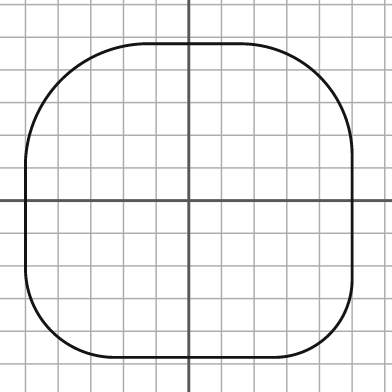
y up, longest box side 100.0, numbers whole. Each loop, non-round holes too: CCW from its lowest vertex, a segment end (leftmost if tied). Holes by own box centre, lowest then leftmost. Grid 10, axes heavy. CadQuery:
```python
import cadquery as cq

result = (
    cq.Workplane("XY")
    .moveTo(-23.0, -48.0)
    .lineTo(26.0, -48.0)
    .threePointArc((43.0, -41.0), (50.0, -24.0))
    .lineTo(50.0, 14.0)
    .threePointArc((40.0, 38.0), (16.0, 48.0))
    .lineTo(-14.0, 48.0)
    .threePointArc((-39.0, 37.0), (-50.0, 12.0))
    .lineTo(-50.0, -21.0)
    .threePointArc((-42.0, -40.0), (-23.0, -48.0))
    .close()
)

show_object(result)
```